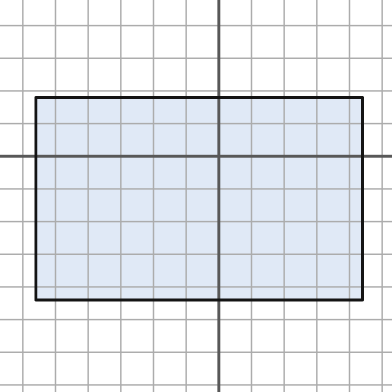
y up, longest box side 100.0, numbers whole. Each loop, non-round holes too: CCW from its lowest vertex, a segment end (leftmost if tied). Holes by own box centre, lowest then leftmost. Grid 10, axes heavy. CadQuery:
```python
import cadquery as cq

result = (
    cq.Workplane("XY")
    .moveTo(-56.0, -44.0)
    .lineTo(44.0, -44.0)
    .lineTo(44.0, 18.0)
    .lineTo(-56.0, 18.0)
    .close()
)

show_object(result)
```